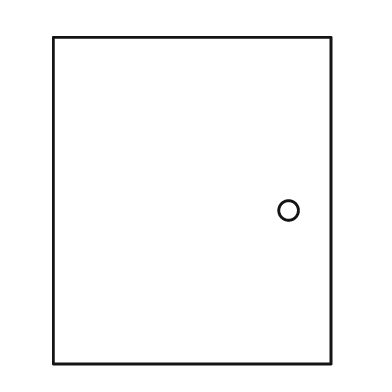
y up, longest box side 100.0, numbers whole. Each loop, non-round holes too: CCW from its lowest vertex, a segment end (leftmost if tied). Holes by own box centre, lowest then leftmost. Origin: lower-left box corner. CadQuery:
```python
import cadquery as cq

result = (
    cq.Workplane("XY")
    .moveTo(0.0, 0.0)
    .lineTo(85.0, 0.0)
    .lineTo(85.0, 100.0)
    .lineTo(0.0, 100.0)
    .close()
    .moveTo(72.0, 47.0)
    .circle(3.0)
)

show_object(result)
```